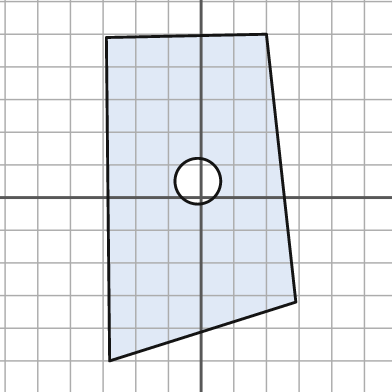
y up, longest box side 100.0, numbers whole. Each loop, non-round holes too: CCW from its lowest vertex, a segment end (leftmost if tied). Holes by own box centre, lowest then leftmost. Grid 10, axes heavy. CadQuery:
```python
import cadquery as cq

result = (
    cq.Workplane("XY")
    .moveTo(-28.0, -50.0)
    .lineTo(29.0, -32.0)
    .lineTo(20.0, 50.0)
    .lineTo(-29.0, 49.0)
    .close()
    .moveTo(-1.0, 5.0)
    .circle(7.0)
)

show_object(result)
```